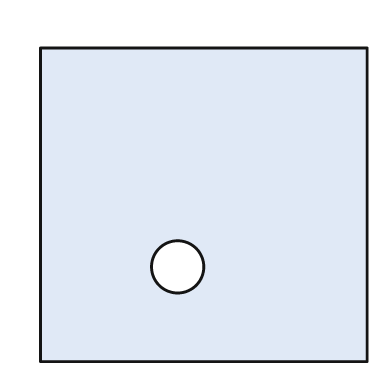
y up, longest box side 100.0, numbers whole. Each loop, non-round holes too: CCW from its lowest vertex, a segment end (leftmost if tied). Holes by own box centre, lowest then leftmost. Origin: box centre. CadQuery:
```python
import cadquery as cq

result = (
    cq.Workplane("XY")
    .moveTo(-50.0, -48.0)
    .lineTo(50.0, -48.0)
    .lineTo(50.0, 48.0)
    .lineTo(-50.0, 48.0)
    .close()
    .moveTo(-8.0, -19.0)
    .circle(8.0)
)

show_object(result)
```